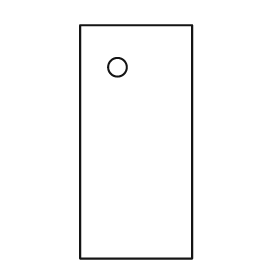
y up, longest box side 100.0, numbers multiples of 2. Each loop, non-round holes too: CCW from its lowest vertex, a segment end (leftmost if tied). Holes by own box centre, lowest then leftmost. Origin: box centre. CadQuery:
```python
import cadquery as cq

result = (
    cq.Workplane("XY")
    .moveTo(-24.0, -50.0)
    .lineTo(24.0, -50.0)
    .lineTo(24.0, 50.0)
    .lineTo(-24.0, 50.0)
    .close()
    .moveTo(-8.0, 32.0)
    .circle(4.0)
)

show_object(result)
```